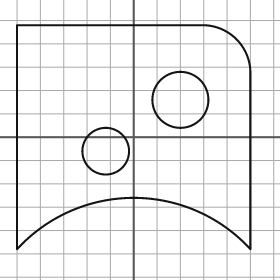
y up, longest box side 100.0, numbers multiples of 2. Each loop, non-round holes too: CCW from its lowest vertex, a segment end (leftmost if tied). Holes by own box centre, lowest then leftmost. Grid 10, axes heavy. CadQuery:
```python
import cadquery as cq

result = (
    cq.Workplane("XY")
    .moveTo(-50.0, -48.0)
    .threePointArc((0.0, -26.0), (50.0, -48.0))
    .lineTo(50.0, 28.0)
    .threePointArc((44.0, 42.0), (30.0, 48.0))
    .lineTo(-50.0, 48.0)
    .close()
    .moveTo(-12.0, -6.0)
    .circle(10.0)
    .moveTo(20.0, 16.0)
    .circle(12.0)
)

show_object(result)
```